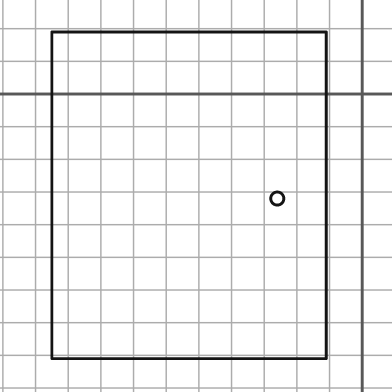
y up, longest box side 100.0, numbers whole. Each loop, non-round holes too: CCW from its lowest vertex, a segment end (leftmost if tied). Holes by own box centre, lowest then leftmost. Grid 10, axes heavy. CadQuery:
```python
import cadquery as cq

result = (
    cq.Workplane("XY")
    .moveTo(-95.0, -81.0)
    .lineTo(-11.0, -81.0)
    .lineTo(-11.0, 19.0)
    .lineTo(-95.0, 19.0)
    .close()
    .moveTo(-26.0, -32.0)
    .circle(2.0)
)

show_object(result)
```